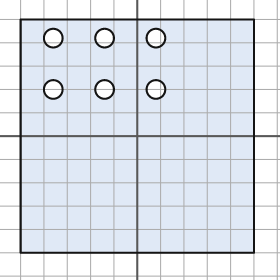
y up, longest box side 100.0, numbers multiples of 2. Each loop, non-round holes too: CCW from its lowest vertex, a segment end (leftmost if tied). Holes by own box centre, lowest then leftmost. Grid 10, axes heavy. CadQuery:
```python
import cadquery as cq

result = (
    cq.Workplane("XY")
    .moveTo(-50.0, -50.0)
    .lineTo(50.0, -50.0)
    .lineTo(50.0, 50.0)
    .lineTo(-50.0, 50.0)
    .close()
    .moveTo(-36.0, 20.0)
    .circle(4.0)
    .moveTo(-14.0, 20.0)
    .circle(4.0)
    .moveTo(8.0, 20.0)
    .circle(4.0)
    .moveTo(-36.0, 42.0)
    .circle(4.0)
    .moveTo(-14.0, 42.0)
    .circle(4.0)
    .moveTo(8.0, 42.0)
    .circle(4.0)
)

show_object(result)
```